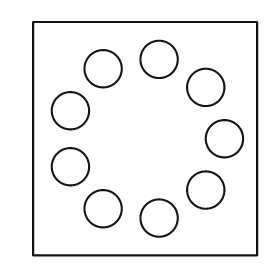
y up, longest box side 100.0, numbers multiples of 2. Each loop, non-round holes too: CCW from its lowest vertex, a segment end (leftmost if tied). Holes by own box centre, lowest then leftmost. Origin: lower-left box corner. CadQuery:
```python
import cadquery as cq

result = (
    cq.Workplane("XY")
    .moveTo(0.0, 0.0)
    .lineTo(96.0, 0.0)
    .lineTo(96.0, 100.0)
    .lineTo(0.0, 100.0)
    .close()
    .moveTo(54.0, 16.0)
    .circle(8.0)
    .moveTo(30.0, 20.0)
    .circle(8.0)
    .moveTo(74.0, 28.0)
    .circle(8.0)
    .moveTo(16.0, 38.0)
    .circle(8.0)
    .moveTo(82.0, 50.0)
    .circle(8.0)
    .moveTo(16.0, 62.0)
    .circle(8.0)
    .moveTo(74.0, 72.0)
    .circle(8.0)
    .moveTo(30.0, 80.0)
    .circle(8.0)
    .moveTo(54.0, 84.0)
    .circle(8.0)
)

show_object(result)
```